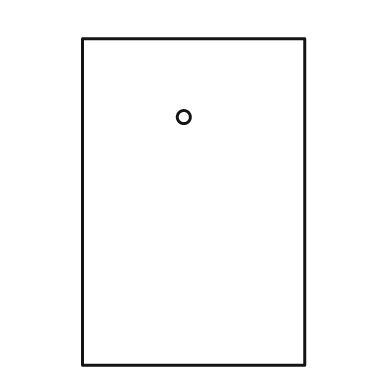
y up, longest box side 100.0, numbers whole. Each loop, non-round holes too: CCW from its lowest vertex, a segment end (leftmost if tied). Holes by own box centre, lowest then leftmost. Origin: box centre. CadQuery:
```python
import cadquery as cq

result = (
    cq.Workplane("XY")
    .moveTo(-34.0, -50.0)
    .lineTo(34.0, -50.0)
    .lineTo(34.0, 50.0)
    .lineTo(-34.0, 50.0)
    .close()
    .moveTo(-3.0, 26.0)
    .circle(2.0)
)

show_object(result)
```